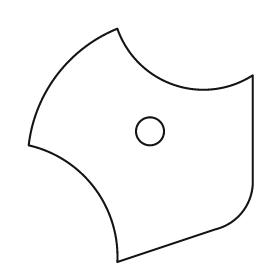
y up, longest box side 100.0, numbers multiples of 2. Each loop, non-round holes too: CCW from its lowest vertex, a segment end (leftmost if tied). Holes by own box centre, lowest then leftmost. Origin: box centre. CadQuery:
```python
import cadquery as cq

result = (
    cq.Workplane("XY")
    .moveTo(-10.0, -50.0)
    .lineTo(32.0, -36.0)
    .threePointArc((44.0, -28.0), (48.0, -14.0))
    .lineTo(48.0, 30.0)
    .threePointArc((14.0, 26.0), (-10.0, 50.0))
    .threePointArc((-36.0, 30.0), (-48.0, 0.0))
    .threePointArc((-20.0, -18.0), (-10.0, -50.0))
    .close()
    .moveTo(4.0, 6.0)
    .circle(6.0)
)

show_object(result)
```